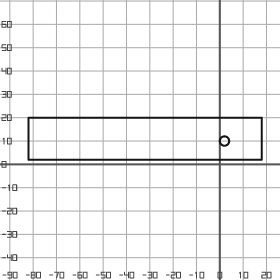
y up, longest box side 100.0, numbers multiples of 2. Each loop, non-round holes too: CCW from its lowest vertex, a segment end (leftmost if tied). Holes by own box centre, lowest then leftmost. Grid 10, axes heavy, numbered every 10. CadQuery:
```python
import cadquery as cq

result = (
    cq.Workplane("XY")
    .moveTo(-82.0, 2.0)
    .lineTo(18.0, 2.0)
    .lineTo(18.0, 20.0)
    .lineTo(-82.0, 20.0)
    .close()
    .moveTo(2.0, 10.0)
    .circle(2.0)
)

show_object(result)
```